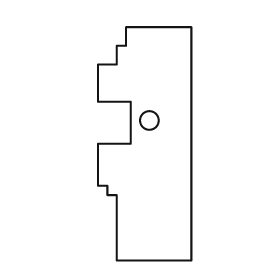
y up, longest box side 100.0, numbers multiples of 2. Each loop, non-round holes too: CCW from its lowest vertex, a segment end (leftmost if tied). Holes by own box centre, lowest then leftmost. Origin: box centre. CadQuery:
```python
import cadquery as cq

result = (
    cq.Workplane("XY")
    .moveTo(-12.0, -50.0)
    .lineTo(20.0, -50.0)
    .lineTo(20.0, 50.0)
    .lineTo(-8.0, 50.0)
    .lineTo(-8.0, 42.0)
    .lineTo(-12.0, 42.0)
    .lineTo(-12.0, 34.0)
    .lineTo(-20.0, 34.0)
    .lineTo(-20.0, 18.0)
    .lineTo(-6.0, 18.0)
    .lineTo(-6.0, 0.0)
    .lineTo(-20.0, 0.0)
    .lineTo(-20.0, -18.0)
    .lineTo(-16.0, -18.0)
    .lineTo(-16.0, -22.0)
    .lineTo(-12.0, -22.0)
    .close()
    .moveTo(2.0, 10.0)
    .circle(4.0)
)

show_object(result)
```